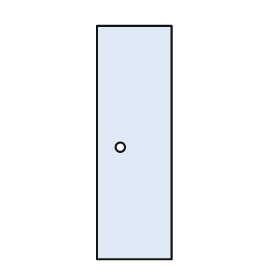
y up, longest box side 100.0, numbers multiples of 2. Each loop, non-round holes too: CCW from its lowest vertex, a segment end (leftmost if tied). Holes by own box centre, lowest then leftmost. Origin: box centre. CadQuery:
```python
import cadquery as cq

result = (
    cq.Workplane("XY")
    .moveTo(-16.0, -50.0)
    .lineTo(16.0, -50.0)
    .lineTo(16.0, 50.0)
    .lineTo(-16.0, 50.0)
    .close()
    .moveTo(-6.0, -2.0)
    .circle(2.0)
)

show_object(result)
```